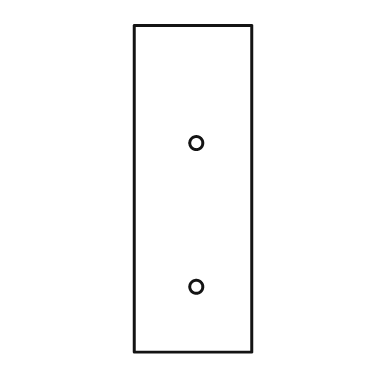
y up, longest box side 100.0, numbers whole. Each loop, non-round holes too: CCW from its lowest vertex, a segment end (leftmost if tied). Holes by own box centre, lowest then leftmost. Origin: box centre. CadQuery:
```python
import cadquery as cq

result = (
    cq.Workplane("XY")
    .moveTo(-18.0, -50.0)
    .lineTo(18.0, -50.0)
    .lineTo(18.0, 50.0)
    .lineTo(-18.0, 50.0)
    .close()
    .moveTo(1.0, -30.0)
    .circle(2.0)
    .moveTo(1.0, 14.0)
    .circle(2.0)
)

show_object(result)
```